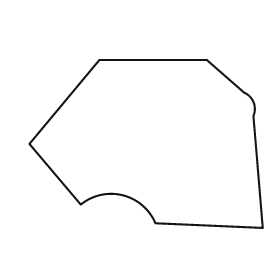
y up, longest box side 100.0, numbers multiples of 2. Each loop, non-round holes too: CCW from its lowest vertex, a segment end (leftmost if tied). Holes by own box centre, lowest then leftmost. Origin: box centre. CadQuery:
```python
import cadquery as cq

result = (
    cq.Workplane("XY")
    .moveTo(50.0, -36.0)
    .lineTo(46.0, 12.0)
    .threePointArc((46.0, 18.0), (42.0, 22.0))
    .lineTo(26.0, 36.0)
    .lineTo(-20.0, 36.0)
    .lineTo(-50.0, 0.0)
    .lineTo(-28.0, -26.0)
    .threePointArc((-10.0, -22.0), (4.0, -34.0))
    .close()
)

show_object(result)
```